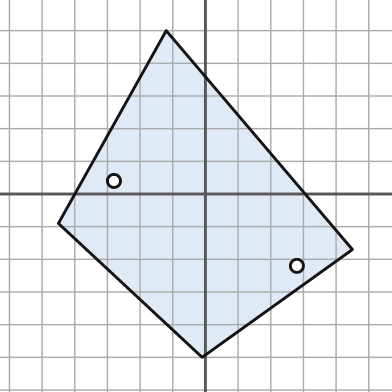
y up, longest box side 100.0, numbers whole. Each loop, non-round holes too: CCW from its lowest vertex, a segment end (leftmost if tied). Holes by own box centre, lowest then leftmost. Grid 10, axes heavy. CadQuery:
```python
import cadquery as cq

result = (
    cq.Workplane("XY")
    .moveTo(-1.0, -50.0)
    .lineTo(45.0, -17.0)
    .lineTo(-12.0, 50.0)
    .lineTo(-45.0, -9.0)
    .close()
    .moveTo(28.0, -22.0)
    .circle(2.0)
    .moveTo(-28.0, 4.0)
    .circle(2.0)
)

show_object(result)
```